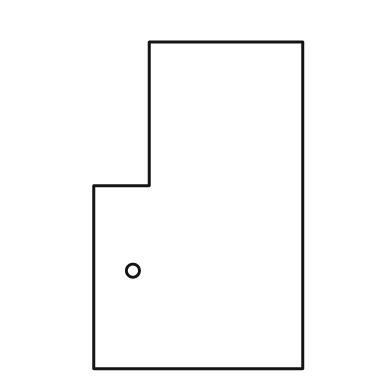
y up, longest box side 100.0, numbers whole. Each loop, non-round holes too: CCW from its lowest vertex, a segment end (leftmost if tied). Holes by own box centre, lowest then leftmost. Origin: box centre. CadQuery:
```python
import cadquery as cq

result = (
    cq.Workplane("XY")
    .moveTo(-32.0, -50.0)
    .lineTo(32.0, -50.0)
    .lineTo(32.0, 50.0)
    .lineTo(-15.0, 50.0)
    .lineTo(-15.0, 6.0)
    .lineTo(-32.0, 6.0)
    .close()
    .moveTo(-20.0, -20.0)
    .circle(2.0)
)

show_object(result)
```